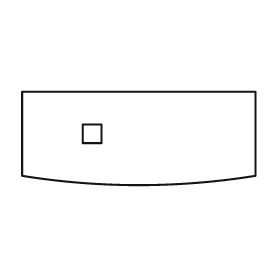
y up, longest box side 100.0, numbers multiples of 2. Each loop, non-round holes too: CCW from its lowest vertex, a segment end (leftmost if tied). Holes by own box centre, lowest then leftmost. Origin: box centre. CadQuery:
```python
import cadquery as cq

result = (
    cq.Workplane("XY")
    .moveTo(-50.0, -16.0)
    .threePointArc((0.0, -20.0), (50.0, -16.0))
    .lineTo(50.0, 20.0)
    .lineTo(-50.0, 20.0)
    .close()
    .moveTo(-24.0, -2.0)
    .lineTo(-16.0, -2.0)
    .lineTo(-16.0, 6.0)
    .lineTo(-24.0, 6.0)
    .close()
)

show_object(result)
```